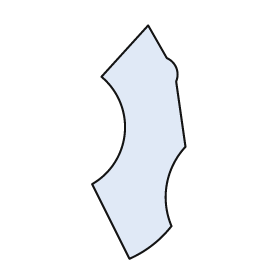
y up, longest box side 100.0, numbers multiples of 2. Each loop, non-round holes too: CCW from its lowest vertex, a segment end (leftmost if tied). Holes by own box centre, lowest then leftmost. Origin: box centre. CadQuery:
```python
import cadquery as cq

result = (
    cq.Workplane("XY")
    .moveTo(-4.0, -50.0)
    .threePointArc((6.0, -44.0), (14.0, -36.0))
    .threePointArc((12.0, -18.0), (20.0, -2.0))
    .lineTo(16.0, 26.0)
    .threePointArc((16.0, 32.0), (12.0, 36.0))
    .lineTo(4.0, 50.0)
    .lineTo(-16.0, 28.0)
    .threePointArc((-6.0, 4.0), (-20.0, -18.0))
    .close()
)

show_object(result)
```